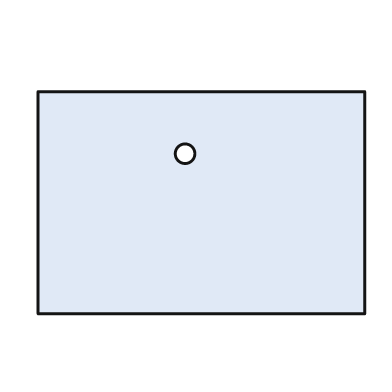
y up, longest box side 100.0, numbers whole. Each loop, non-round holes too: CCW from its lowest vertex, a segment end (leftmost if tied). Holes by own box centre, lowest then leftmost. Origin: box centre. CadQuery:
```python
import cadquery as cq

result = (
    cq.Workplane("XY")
    .moveTo(-50.0, -34.0)
    .lineTo(50.0, -34.0)
    .lineTo(50.0, 34.0)
    .lineTo(-50.0, 34.0)
    .close()
    .moveTo(-5.0, 15.0)
    .circle(3.0)
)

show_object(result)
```